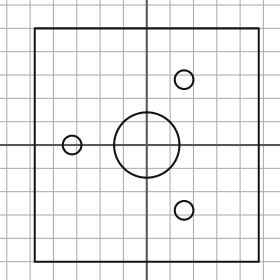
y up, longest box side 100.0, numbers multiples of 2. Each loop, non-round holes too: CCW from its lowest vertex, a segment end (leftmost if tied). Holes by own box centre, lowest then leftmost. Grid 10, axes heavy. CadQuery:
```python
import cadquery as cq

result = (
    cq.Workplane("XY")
    .moveTo(-48.0, -50.0)
    .lineTo(48.0, -50.0)
    .lineTo(48.0, 50.0)
    .lineTo(-48.0, 50.0)
    .close()
    .moveTo(16.0, -28.0)
    .circle(4.0)
    .moveTo(-32.0, 0.0)
    .circle(4.0)
    .moveTo(0.0, 0.0)
    .circle(14.0)
    .moveTo(16.0, 28.0)
    .circle(4.0)
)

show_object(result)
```